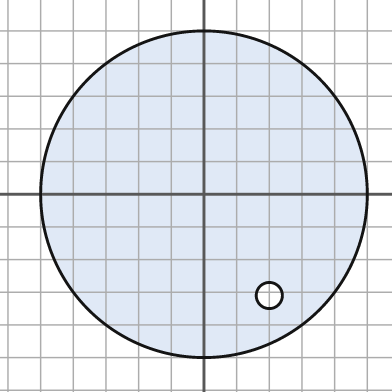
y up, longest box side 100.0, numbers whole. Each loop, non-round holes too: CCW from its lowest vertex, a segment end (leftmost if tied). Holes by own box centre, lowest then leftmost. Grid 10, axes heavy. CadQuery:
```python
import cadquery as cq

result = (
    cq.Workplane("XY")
    .moveTo(0.0, 0.0)
    .circle(50.0)
    .moveTo(20.0, -31.0)
    .circle(4.0)
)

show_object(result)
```